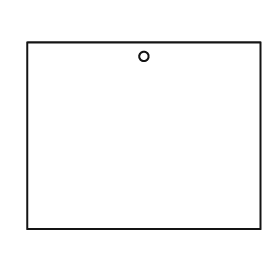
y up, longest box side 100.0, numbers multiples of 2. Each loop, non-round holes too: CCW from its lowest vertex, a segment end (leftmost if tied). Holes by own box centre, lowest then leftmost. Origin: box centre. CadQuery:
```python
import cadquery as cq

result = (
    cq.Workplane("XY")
    .moveTo(-50.0, -40.0)
    .lineTo(50.0, -40.0)
    .lineTo(50.0, 40.0)
    .lineTo(-50.0, 40.0)
    .close()
    .moveTo(0.0, 34.0)
    .circle(2.0)
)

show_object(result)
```